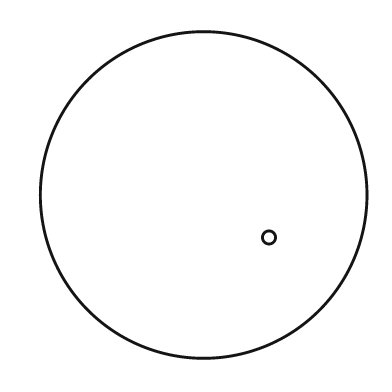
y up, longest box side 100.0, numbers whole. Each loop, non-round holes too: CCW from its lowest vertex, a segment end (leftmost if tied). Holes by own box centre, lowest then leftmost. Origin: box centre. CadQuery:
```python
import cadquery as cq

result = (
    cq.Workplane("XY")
    .moveTo(0.0, 0.0)
    .circle(50.0)
    .moveTo(20.0, -13.0)
    .circle(2.0)
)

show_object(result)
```